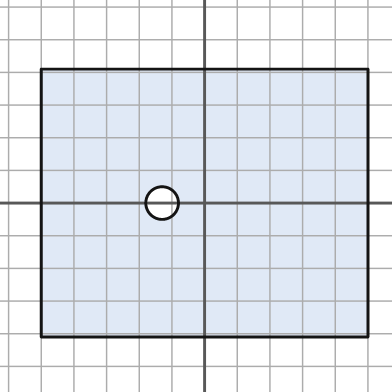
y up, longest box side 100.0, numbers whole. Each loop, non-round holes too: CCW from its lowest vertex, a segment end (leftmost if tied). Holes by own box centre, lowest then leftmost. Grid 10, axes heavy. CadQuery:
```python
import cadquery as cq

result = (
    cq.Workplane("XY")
    .moveTo(-50.0, -41.0)
    .lineTo(50.0, -41.0)
    .lineTo(50.0, 41.0)
    .lineTo(-50.0, 41.0)
    .close()
    .moveTo(-13.0, 0.0)
    .circle(5.0)
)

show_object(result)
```